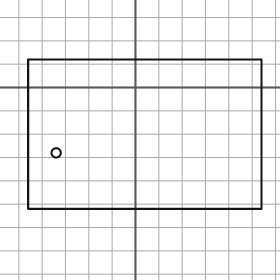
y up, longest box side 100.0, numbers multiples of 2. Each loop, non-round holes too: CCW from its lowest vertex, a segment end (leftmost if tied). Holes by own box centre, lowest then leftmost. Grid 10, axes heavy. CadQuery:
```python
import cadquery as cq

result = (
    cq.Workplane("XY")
    .moveTo(-46.0, -52.0)
    .lineTo(54.0, -52.0)
    .lineTo(54.0, 12.0)
    .lineTo(-46.0, 12.0)
    .close()
    .moveTo(-34.0, -28.0)
    .circle(2.0)
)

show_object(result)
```